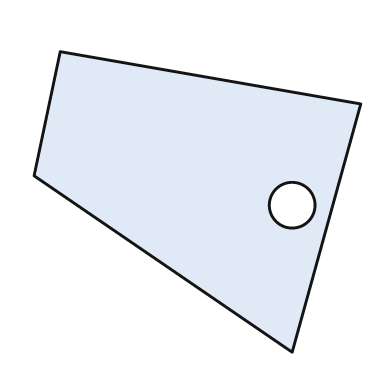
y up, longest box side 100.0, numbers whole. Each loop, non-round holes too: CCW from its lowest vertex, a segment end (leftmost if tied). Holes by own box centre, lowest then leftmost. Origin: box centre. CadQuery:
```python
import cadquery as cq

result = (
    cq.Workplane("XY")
    .moveTo(29.0, -46.0)
    .lineTo(50.0, 30.0)
    .lineTo(-42.0, 46.0)
    .lineTo(-50.0, 8.0)
    .close()
    .moveTo(29.0, -1.0)
    .circle(7.0)
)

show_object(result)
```